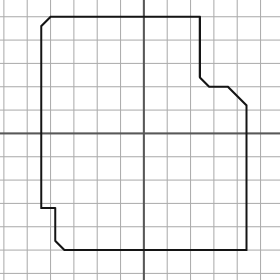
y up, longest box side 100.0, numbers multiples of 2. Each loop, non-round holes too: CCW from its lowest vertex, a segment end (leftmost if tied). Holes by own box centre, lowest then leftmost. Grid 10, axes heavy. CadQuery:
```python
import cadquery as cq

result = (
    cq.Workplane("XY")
    .moveTo(-34.0, -50.0)
    .lineTo(44.0, -50.0)
    .lineTo(44.0, 12.0)
    .lineTo(36.0, 20.0)
    .lineTo(28.0, 20.0)
    .lineTo(24.0, 24.0)
    .lineTo(24.0, 50.0)
    .lineTo(-40.0, 50.0)
    .lineTo(-44.0, 46.0)
    .lineTo(-44.0, -32.0)
    .lineTo(-38.0, -32.0)
    .lineTo(-38.0, -46.0)
    .close()
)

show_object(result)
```